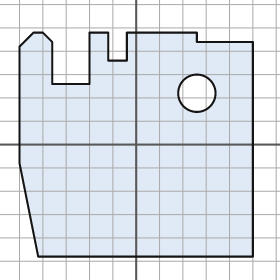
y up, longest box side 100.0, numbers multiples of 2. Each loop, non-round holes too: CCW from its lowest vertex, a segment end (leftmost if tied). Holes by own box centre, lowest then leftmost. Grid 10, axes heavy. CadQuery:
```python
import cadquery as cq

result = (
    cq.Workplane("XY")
    .moveTo(-42.0, -48.0)
    .lineTo(50.0, -48.0)
    .lineTo(50.0, 44.0)
    .lineTo(26.0, 44.0)
    .lineTo(26.0, 48.0)
    .lineTo(-4.0, 48.0)
    .lineTo(-4.0, 36.0)
    .lineTo(-12.0, 36.0)
    .lineTo(-12.0, 48.0)
    .lineTo(-20.0, 48.0)
    .lineTo(-20.0, 26.0)
    .lineTo(-36.0, 26.0)
    .lineTo(-36.0, 44.0)
    .lineTo(-40.0, 48.0)
    .lineTo(-44.0, 48.0)
    .lineTo(-50.0, 42.0)
    .lineTo(-50.0, -8.0)
    .close()
    .moveTo(26.0, 22.0)
    .circle(8.0)
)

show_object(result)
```